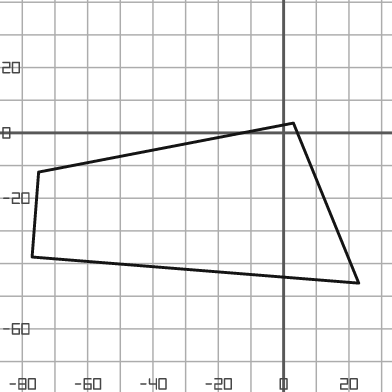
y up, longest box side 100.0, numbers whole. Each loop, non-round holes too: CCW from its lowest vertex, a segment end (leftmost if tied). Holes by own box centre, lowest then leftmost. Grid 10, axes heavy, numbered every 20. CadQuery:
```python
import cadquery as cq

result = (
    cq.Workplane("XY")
    .moveTo(23.0, -46.0)
    .lineTo(3.0, 3.0)
    .lineTo(-75.0, -12.0)
    .lineTo(-77.0, -38.0)
    .close()
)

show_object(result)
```